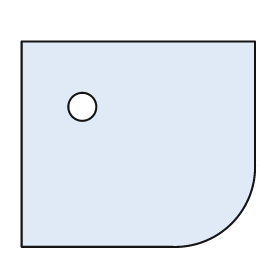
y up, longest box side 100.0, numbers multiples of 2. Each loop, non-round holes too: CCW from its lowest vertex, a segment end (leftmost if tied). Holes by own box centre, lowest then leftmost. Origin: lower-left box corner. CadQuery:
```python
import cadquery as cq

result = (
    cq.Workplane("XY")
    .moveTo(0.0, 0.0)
    .lineTo(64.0, 0.0)
    .threePointArc((90.0, 10.0), (100.0, 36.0))
    .lineTo(100.0, 88.0)
    .lineTo(0.0, 88.0)
    .close()
    .moveTo(26.0, 60.0)
    .circle(6.0)
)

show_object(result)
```